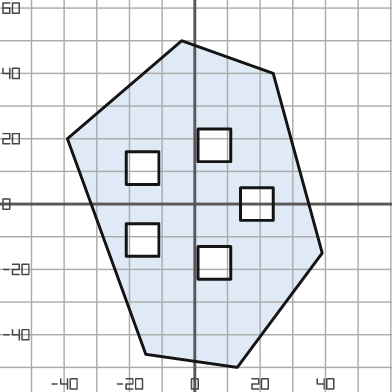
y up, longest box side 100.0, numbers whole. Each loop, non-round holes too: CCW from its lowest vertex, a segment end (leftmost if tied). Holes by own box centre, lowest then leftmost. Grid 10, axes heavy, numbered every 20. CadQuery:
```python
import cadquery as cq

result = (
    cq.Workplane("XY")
    .moveTo(13.0, -50.0)
    .lineTo(39.0, -15.0)
    .lineTo(24.0, 40.0)
    .lineTo(-4.0, 50.0)
    .lineTo(-39.0, 20.0)
    .lineTo(-15.0, -46.0)
    .close()
    .moveTo(1.0, -23.0)
    .lineTo(11.0, -23.0)
    .lineTo(11.0, -13.0)
    .lineTo(1.0, -13.0)
    .close()
    .moveTo(-21.0, -16.0)
    .lineTo(-11.0, -16.0)
    .lineTo(-11.0, -6.0)
    .lineTo(-21.0, -6.0)
    .close()
    .moveTo(14.0, -5.0)
    .lineTo(24.0, -5.0)
    .lineTo(24.0, 5.0)
    .lineTo(14.0, 5.0)
    .close()
    .moveTo(-21.0, 6.0)
    .lineTo(-11.0, 6.0)
    .lineTo(-11.0, 16.0)
    .lineTo(-21.0, 16.0)
    .close()
    .moveTo(1.0, 13.0)
    .lineTo(11.0, 13.0)
    .lineTo(11.0, 23.0)
    .lineTo(1.0, 23.0)
    .close()
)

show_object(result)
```